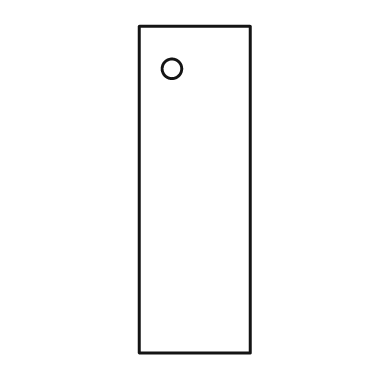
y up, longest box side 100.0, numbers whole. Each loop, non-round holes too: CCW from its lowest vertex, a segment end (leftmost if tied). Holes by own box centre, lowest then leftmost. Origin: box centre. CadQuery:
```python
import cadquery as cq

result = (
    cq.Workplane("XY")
    .moveTo(-17.0, -50.0)
    .lineTo(17.0, -50.0)
    .lineTo(17.0, 50.0)
    .lineTo(-17.0, 50.0)
    .close()
    .moveTo(-7.0, 37.0)
    .circle(3.0)
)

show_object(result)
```